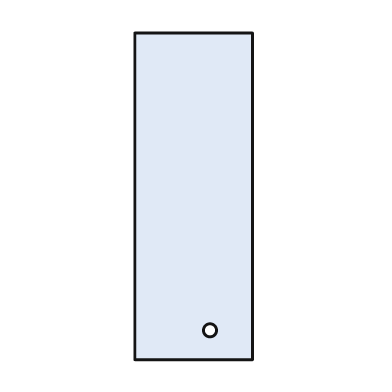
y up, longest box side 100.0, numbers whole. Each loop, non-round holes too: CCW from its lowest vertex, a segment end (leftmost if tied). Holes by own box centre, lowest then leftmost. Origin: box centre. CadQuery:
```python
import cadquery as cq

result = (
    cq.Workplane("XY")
    .moveTo(-18.0, -50.0)
    .lineTo(18.0, -50.0)
    .lineTo(18.0, 50.0)
    .lineTo(-18.0, 50.0)
    .close()
    .moveTo(5.0, -41.0)
    .circle(2.0)
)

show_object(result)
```